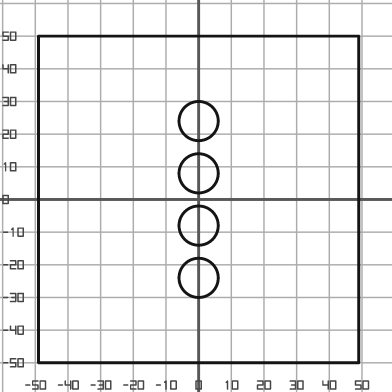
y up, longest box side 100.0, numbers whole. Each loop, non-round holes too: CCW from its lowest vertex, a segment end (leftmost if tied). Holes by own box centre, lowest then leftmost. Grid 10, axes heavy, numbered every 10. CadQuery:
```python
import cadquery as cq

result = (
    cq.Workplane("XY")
    .moveTo(-49.0, -50.0)
    .lineTo(49.0, -50.0)
    .lineTo(49.0, 50.0)
    .lineTo(-49.0, 50.0)
    .close()
    .moveTo(0.0, -24.0)
    .circle(6.0)
    .moveTo(0.0, -8.0)
    .circle(6.0)
    .moveTo(0.0, 8.0)
    .circle(6.0)
    .moveTo(0.0, 24.0)
    .circle(6.0)
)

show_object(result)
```